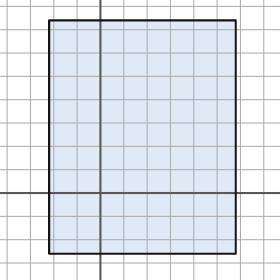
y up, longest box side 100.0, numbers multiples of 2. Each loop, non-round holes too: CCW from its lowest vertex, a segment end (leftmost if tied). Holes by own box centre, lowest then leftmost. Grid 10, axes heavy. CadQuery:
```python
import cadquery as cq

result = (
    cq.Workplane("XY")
    .moveTo(-22.0, -26.0)
    .lineTo(58.0, -26.0)
    .lineTo(58.0, 74.0)
    .lineTo(-22.0, 74.0)
    .close()
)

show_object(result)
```